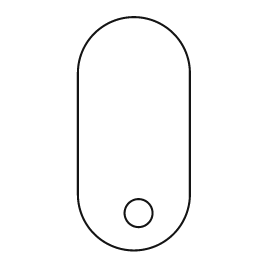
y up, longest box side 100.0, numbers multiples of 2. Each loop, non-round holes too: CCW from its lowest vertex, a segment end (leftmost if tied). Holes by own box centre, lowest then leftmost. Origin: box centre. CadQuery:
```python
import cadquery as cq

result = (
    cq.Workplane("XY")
    .moveTo(-24.0, -26.0)
    .threePointArc((0.0, -50.0), (24.0, -26.0))
    .lineTo(24.0, 26.0)
    .threePointArc((0.0, 50.0), (-24.0, 26.0))
    .close()
    .moveTo(2.0, -34.0)
    .circle(6.0)
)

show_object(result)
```